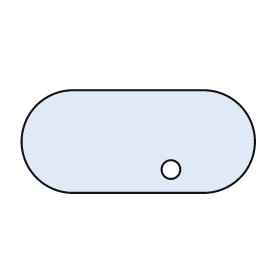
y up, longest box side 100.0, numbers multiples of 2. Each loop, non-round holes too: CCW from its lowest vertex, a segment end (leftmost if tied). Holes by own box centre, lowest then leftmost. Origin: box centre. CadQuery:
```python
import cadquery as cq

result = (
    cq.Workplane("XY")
    .moveTo(-28.0, -22.0)
    .lineTo(28.0, -22.0)
    .threePointArc((50.0, 0.0), (28.0, 22.0))
    .lineTo(-28.0, 22.0)
    .threePointArc((-50.0, 0.0), (-28.0, -22.0))
    .close()
    .moveTo(14.0, -12.0)
    .circle(4.0)
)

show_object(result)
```